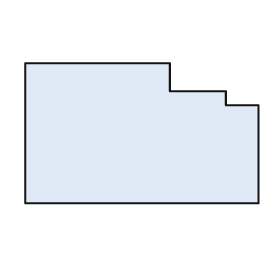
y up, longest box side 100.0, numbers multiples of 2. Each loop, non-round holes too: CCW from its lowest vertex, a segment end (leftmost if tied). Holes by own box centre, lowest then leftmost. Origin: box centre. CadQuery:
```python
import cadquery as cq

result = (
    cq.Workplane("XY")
    .moveTo(-50.0, -30.0)
    .lineTo(50.0, -30.0)
    .lineTo(50.0, 12.0)
    .lineTo(36.0, 12.0)
    .lineTo(36.0, 18.0)
    .lineTo(12.0, 18.0)
    .lineTo(12.0, 30.0)
    .lineTo(-50.0, 30.0)
    .close()
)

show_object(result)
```